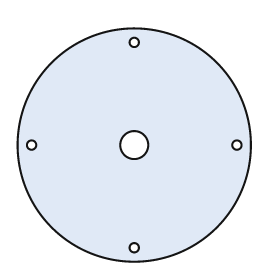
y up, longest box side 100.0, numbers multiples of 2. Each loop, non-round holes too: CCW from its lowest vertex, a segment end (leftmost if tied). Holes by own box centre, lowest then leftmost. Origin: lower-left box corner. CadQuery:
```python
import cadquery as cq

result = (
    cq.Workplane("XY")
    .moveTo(50.0, 50.0)
    .circle(50.0)
    .moveTo(50.0, 6.0)
    .circle(2.0)
    .moveTo(6.0, 50.0)
    .circle(2.0)
    .moveTo(50.0, 50.0)
    .circle(6.0)
    .moveTo(94.0, 50.0)
    .circle(2.0)
    .moveTo(50.0, 94.0)
    .circle(2.0)
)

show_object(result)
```